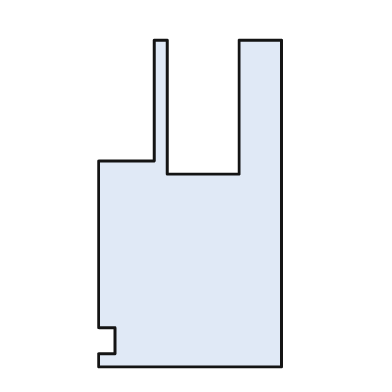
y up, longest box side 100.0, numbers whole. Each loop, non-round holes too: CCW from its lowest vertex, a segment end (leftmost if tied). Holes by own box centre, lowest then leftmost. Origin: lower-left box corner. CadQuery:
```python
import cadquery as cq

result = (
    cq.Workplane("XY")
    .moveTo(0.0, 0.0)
    .lineTo(56.0, 0.0)
    .lineTo(56.0, 100.0)
    .lineTo(43.0, 100.0)
    .lineTo(43.0, 59.0)
    .lineTo(21.0, 59.0)
    .lineTo(21.0, 100.0)
    .lineTo(17.0, 100.0)
    .lineTo(17.0, 63.0)
    .lineTo(0.0, 63.0)
    .lineTo(0.0, 12.0)
    .lineTo(5.0, 12.0)
    .lineTo(5.0, 4.0)
    .lineTo(0.0, 4.0)
    .close()
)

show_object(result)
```